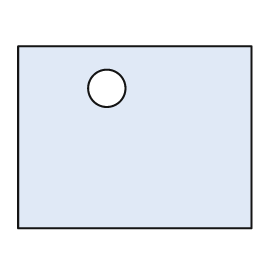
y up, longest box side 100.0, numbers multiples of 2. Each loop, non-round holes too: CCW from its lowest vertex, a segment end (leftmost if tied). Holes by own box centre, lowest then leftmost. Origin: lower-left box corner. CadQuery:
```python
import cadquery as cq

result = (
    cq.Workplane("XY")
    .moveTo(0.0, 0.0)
    .lineTo(100.0, 0.0)
    .lineTo(100.0, 78.0)
    .lineTo(0.0, 78.0)
    .close()
    .moveTo(38.0, 60.0)
    .circle(8.0)
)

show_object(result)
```